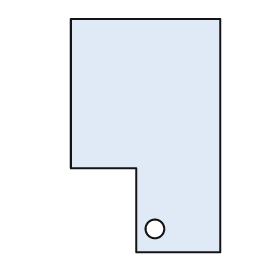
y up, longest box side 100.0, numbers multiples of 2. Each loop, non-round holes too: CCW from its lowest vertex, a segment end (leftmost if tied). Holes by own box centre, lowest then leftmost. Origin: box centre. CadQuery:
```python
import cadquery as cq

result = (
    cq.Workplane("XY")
    .moveTo(-4.0, -50.0)
    .lineTo(32.0, -50.0)
    .lineTo(32.0, 50.0)
    .lineTo(-32.0, 50.0)
    .lineTo(-32.0, -14.0)
    .lineTo(-4.0, -14.0)
    .close()
    .moveTo(4.0, -40.0)
    .circle(4.0)
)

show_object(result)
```